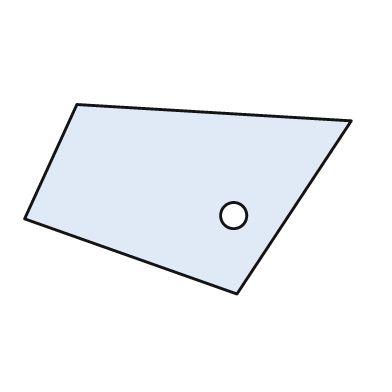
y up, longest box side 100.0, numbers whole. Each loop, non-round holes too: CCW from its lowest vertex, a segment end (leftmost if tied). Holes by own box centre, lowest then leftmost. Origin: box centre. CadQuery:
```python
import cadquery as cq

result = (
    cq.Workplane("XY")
    .moveTo(15.0, -29.0)
    .lineTo(50.0, 24.0)
    .lineTo(-34.0, 29.0)
    .lineTo(-50.0, -6.0)
    .close()
    .moveTo(14.0, -5.0)
    .circle(4.0)
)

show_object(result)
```